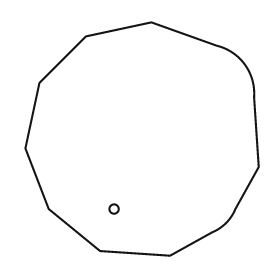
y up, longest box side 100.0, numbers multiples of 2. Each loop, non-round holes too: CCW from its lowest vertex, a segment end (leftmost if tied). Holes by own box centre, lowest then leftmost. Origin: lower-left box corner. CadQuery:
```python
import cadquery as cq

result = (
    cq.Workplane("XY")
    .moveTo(62.0, 0.0)
    .lineTo(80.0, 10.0)
    .threePointArc((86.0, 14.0), (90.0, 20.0))
    .lineTo(100.0, 38.0)
    .lineTo(98.0, 68.0)
    .threePointArc((94.0, 82.0), (82.0, 90.0))
    .lineTo(54.0, 100.0)
    .lineTo(26.0, 94.0)
    .lineTo(6.0, 74.0)
    .lineTo(0.0, 46.0)
    .lineTo(10.0, 20.0)
    .lineTo(32.0, 2.0)
    .close()
    .moveTo(38.0, 20.0)
    .circle(2.0)
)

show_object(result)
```